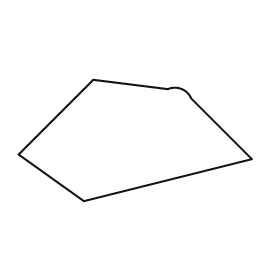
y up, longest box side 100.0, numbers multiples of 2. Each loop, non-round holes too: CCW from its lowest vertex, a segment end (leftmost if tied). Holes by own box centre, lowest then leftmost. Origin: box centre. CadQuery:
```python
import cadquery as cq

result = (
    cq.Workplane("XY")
    .moveTo(-22.0, -26.0)
    .lineTo(50.0, -8.0)
    .lineTo(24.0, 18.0)
    .threePointArc((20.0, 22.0), (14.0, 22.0))
    .lineTo(-18.0, 26.0)
    .lineTo(-50.0, -6.0)
    .close()
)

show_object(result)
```